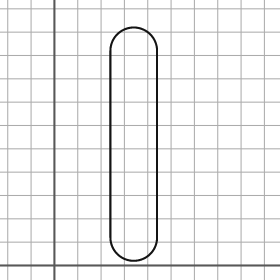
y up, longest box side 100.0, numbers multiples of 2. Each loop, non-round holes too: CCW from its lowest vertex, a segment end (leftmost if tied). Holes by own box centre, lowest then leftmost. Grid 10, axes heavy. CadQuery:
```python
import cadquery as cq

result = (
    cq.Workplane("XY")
    .moveTo(24.0, 12.0)
    .threePointArc((34.0, 2.0), (44.0, 12.0))
    .lineTo(44.0, 92.0)
    .threePointArc((34.0, 102.0), (24.0, 92.0))
    .close()
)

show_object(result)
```